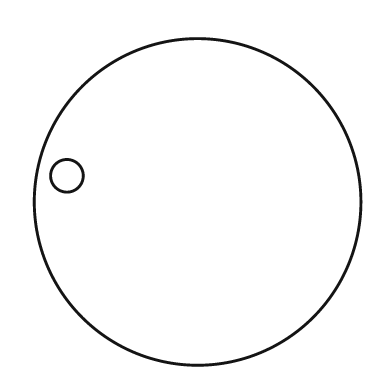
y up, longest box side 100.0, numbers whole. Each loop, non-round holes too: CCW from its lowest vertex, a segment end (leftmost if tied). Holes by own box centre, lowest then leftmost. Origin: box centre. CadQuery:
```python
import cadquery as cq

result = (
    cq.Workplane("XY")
    .moveTo(0.0, 0.0)
    .circle(50.0)
    .moveTo(-40.0, 8.0)
    .circle(5.0)
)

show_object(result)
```